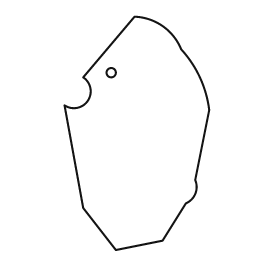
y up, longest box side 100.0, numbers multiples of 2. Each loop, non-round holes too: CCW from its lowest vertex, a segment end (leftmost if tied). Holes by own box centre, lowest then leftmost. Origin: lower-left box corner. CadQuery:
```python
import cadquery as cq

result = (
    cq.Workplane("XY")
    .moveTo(22.0, 0.0)
    .lineTo(42.0, 4.0)
    .lineTo(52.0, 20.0)
    .threePointArc((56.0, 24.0), (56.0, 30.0))
    .lineTo(62.0, 60.0)
    .threePointArc((58.0, 74.0), (50.0, 86.0))
    .threePointArc((42.0, 96.0), (30.0, 100.0))
    .lineTo(8.0, 74.0)
    .threePointArc((10.0, 64.0), (0.0, 62.0))
    .lineTo(8.0, 18.0)
    .close()
    .moveTo(20.0, 76.0)
    .circle(2.0)
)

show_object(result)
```